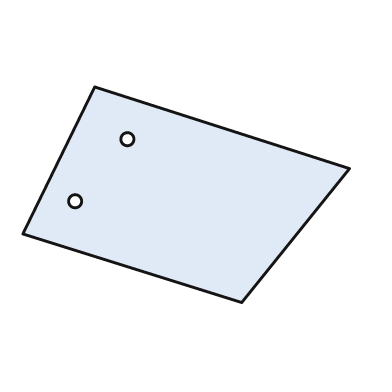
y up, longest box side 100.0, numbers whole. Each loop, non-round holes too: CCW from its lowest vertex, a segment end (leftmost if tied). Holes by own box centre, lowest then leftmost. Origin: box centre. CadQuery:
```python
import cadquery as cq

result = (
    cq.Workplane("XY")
    .moveTo(17.0, -33.0)
    .lineTo(50.0, 8.0)
    .lineTo(-28.0, 33.0)
    .lineTo(-50.0, -12.0)
    .close()
    .moveTo(-34.0, -2.0)
    .circle(2.0)
    .moveTo(-18.0, 17.0)
    .circle(2.0)
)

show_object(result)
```